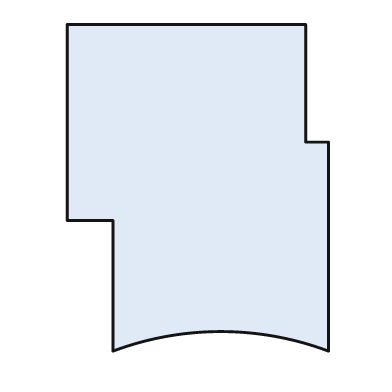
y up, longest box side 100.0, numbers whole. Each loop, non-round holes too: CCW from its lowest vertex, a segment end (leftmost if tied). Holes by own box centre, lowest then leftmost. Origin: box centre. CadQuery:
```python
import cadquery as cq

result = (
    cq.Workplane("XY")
    .moveTo(-26.0, -50.0)
    .threePointArc((7.0, -44.0), (40.0, -50.0))
    .lineTo(40.0, 14.0)
    .lineTo(33.0, 14.0)
    .lineTo(33.0, 50.0)
    .lineTo(-40.0, 50.0)
    .lineTo(-40.0, -10.0)
    .lineTo(-26.0, -10.0)
    .close()
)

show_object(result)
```